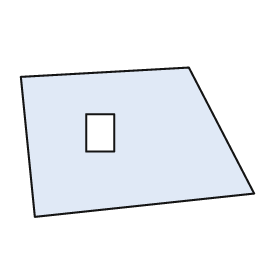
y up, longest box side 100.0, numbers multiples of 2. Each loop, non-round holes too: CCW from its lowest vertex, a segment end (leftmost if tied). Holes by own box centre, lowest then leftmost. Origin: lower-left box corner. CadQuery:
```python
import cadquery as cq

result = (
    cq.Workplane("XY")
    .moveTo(6.0, 0.0)
    .lineTo(100.0, 10.0)
    .lineTo(72.0, 64.0)
    .lineTo(0.0, 60.0)
    .close()
    .moveTo(28.0, 28.0)
    .lineTo(40.0, 28.0)
    .lineTo(40.0, 44.0)
    .lineTo(28.0, 44.0)
    .close()
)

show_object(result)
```